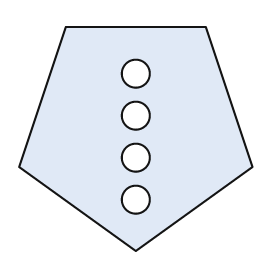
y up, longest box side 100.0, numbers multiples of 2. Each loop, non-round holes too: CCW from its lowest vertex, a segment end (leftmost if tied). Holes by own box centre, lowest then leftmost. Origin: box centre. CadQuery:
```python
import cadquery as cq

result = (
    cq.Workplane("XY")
    .moveTo(0.0, -48.0)
    .lineTo(50.0, -12.0)
    .lineTo(30.0, 48.0)
    .lineTo(-30.0, 48.0)
    .lineTo(-50.0, -12.0)
    .close()
    .moveTo(0.0, -26.0)
    .circle(6.0)
    .moveTo(0.0, -8.0)
    .circle(6.0)
    .moveTo(0.0, 10.0)
    .circle(6.0)
    .moveTo(0.0, 28.0)
    .circle(6.0)
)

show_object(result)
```